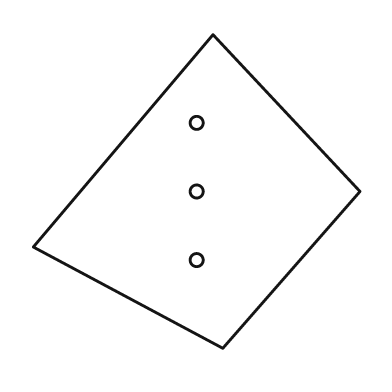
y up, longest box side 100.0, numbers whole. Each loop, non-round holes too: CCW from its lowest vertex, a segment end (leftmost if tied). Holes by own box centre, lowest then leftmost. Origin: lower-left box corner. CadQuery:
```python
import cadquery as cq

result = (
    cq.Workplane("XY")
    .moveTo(58.0, 0.0)
    .lineTo(100.0, 48.0)
    .lineTo(55.0, 96.0)
    .lineTo(0.0, 31.0)
    .close()
    .moveTo(50.0, 27.0)
    .circle(2.0)
    .moveTo(50.0, 48.0)
    .circle(2.0)
    .moveTo(50.0, 69.0)
    .circle(2.0)
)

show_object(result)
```